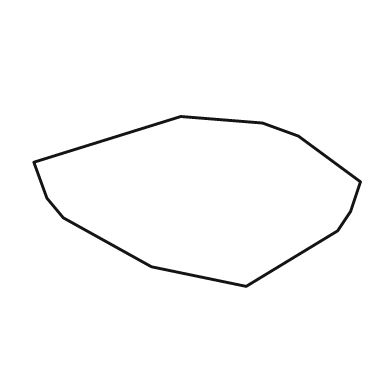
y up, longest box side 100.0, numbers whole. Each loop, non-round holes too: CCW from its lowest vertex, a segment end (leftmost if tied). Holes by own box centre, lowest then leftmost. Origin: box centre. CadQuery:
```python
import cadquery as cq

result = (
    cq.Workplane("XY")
    .moveTo(15.0, -26.0)
    .lineTo(43.0, -9.0)
    .lineTo(47.0, -3.0)
    .lineTo(50.0, 6.0)
    .lineTo(31.0, 20.0)
    .lineTo(20.0, 24.0)
    .lineTo(-5.0, 26.0)
    .lineTo(-50.0, 12.0)
    .lineTo(-46.0, 1.0)
    .lineTo(-41.0, -5.0)
    .lineTo(-14.0, -20.0)
    .close()
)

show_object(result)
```